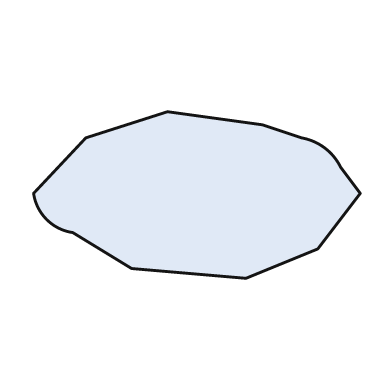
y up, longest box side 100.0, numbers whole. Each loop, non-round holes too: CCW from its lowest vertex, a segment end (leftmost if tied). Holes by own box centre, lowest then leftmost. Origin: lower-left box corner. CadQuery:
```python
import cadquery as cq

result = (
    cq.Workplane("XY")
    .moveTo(65.0, 0.0)
    .lineTo(87.0, 9.0)
    .lineTo(100.0, 26.0)
    .lineTo(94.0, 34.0)
    .threePointArc((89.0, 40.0), (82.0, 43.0))
    .lineTo(70.0, 47.0)
    .lineTo(41.0, 51.0)
    .lineTo(16.0, 43.0)
    .lineTo(0.0, 26.0)
    .threePointArc((4.0, 18.0), (12.0, 14.0))
    .lineTo(30.0, 3.0)
    .close()
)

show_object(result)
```